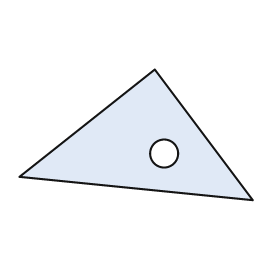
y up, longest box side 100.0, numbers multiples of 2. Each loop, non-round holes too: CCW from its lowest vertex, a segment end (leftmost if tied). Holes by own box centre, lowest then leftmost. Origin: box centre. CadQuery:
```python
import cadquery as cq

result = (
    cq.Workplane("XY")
    .moveTo(50.0, -28.0)
    .lineTo(8.0, 28.0)
    .lineTo(-50.0, -18.0)
    .close()
    .moveTo(12.0, -8.0)
    .circle(6.0)
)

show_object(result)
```